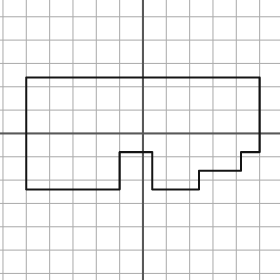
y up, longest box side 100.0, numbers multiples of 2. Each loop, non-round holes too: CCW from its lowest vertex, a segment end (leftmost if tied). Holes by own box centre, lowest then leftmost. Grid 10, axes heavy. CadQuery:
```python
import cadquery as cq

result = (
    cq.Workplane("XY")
    .moveTo(-50.0, -24.0)
    .lineTo(-10.0, -24.0)
    .lineTo(-10.0, -8.0)
    .lineTo(4.0, -8.0)
    .lineTo(4.0, -24.0)
    .lineTo(24.0, -24.0)
    .lineTo(24.0, -16.0)
    .lineTo(42.0, -16.0)
    .lineTo(42.0, -8.0)
    .lineTo(50.0, -8.0)
    .lineTo(50.0, 24.0)
    .lineTo(-50.0, 24.0)
    .close()
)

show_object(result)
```